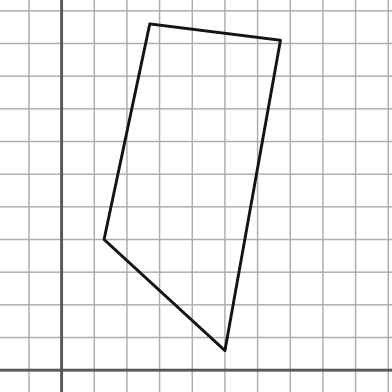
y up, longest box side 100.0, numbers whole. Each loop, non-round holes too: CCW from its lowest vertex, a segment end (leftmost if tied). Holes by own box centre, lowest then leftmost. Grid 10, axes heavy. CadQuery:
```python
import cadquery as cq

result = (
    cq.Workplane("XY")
    .moveTo(50.0, 6.0)
    .lineTo(67.0, 101.0)
    .lineTo(27.0, 106.0)
    .lineTo(13.0, 40.0)
    .close()
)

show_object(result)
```